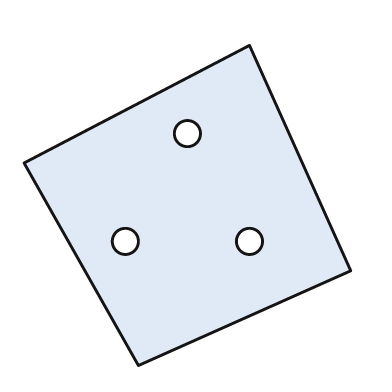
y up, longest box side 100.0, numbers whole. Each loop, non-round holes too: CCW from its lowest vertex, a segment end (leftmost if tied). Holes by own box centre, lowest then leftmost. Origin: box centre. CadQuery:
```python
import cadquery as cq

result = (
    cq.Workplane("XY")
    .moveTo(-15.0, -49.0)
    .lineTo(50.0, -20.0)
    .lineTo(19.0, 49.0)
    .lineTo(-50.0, 13.0)
    .close()
    .moveTo(-19.0, -11.0)
    .circle(4.0)
    .moveTo(19.0, -11.0)
    .circle(4.0)
    .moveTo(0.0, 22.0)
    .circle(4.0)
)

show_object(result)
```